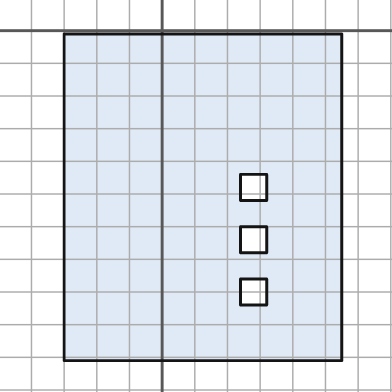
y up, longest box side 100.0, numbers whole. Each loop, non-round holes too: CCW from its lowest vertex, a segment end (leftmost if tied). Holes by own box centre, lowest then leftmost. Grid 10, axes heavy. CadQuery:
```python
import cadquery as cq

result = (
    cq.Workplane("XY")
    .moveTo(-30.0, -101.0)
    .lineTo(55.0, -101.0)
    .lineTo(55.0, -1.0)
    .lineTo(-30.0, -1.0)
    .close()
    .moveTo(24.0, -84.0)
    .lineTo(32.0, -84.0)
    .lineTo(32.0, -76.0)
    .lineTo(24.0, -76.0)
    .close()
    .moveTo(24.0, -68.0)
    .lineTo(32.0, -68.0)
    .lineTo(32.0, -60.0)
    .lineTo(24.0, -60.0)
    .close()
    .moveTo(24.0, -52.0)
    .lineTo(32.0, -52.0)
    .lineTo(32.0, -44.0)
    .lineTo(24.0, -44.0)
    .close()
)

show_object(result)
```